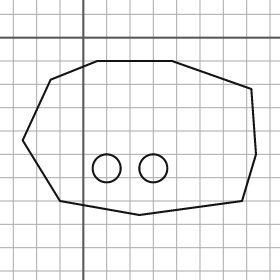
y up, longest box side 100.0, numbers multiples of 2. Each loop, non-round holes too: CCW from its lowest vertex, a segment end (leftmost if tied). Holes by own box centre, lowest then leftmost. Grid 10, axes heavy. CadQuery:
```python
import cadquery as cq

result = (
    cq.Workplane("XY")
    .moveTo(24.0, -76.0)
    .lineTo(68.0, -70.0)
    .lineTo(74.0, -50.0)
    .lineTo(72.0, -22.0)
    .lineTo(38.0, -10.0)
    .lineTo(6.0, -10.0)
    .lineTo(-14.0, -18.0)
    .lineTo(-26.0, -44.0)
    .lineTo(-10.0, -70.0)
    .close()
    .moveTo(10.0, -56.0)
    .circle(6.0)
    .moveTo(30.0, -56.0)
    .circle(6.0)
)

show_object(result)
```